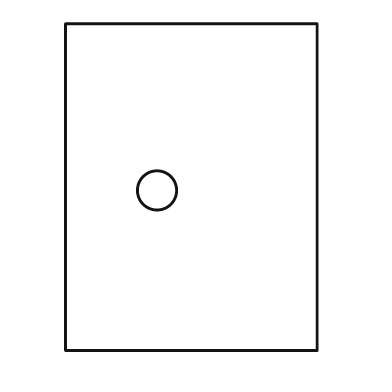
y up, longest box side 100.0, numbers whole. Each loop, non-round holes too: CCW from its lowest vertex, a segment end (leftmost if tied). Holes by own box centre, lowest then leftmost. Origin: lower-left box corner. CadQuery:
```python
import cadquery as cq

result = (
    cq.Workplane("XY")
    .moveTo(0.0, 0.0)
    .lineTo(77.0, 0.0)
    .lineTo(77.0, 100.0)
    .lineTo(0.0, 100.0)
    .close()
    .moveTo(28.0, 49.0)
    .circle(6.0)
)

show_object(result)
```